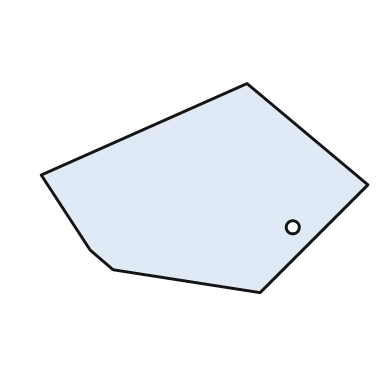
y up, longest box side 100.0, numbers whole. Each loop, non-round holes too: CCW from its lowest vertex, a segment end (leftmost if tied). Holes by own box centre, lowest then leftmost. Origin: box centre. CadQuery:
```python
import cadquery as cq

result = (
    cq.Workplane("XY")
    .moveTo(17.0, -32.0)
    .lineTo(50.0, 1.0)
    .lineTo(13.0, 32.0)
    .lineTo(-50.0, 4.0)
    .lineTo(-35.0, -19.0)
    .lineTo(-28.0, -25.0)
    .close()
    .moveTo(27.0, -12.0)
    .circle(2.0)
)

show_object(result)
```